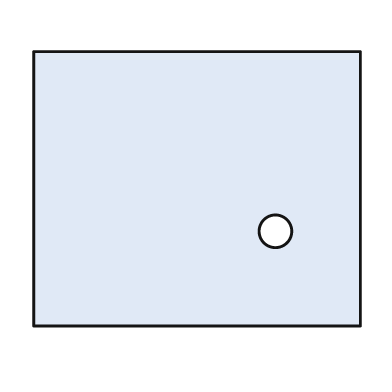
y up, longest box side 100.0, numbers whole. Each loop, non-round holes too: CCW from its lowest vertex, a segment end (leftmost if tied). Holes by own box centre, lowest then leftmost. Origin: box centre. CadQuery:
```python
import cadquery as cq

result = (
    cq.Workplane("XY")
    .moveTo(-50.0, -42.0)
    .lineTo(50.0, -42.0)
    .lineTo(50.0, 42.0)
    .lineTo(-50.0, 42.0)
    .close()
    .moveTo(24.0, -13.0)
    .circle(5.0)
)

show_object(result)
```